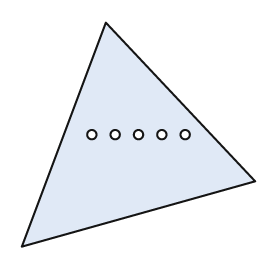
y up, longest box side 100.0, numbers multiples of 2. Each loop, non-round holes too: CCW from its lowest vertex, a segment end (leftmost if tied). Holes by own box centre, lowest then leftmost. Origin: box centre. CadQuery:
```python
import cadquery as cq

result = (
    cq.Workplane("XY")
    .moveTo(-50.0, -48.0)
    .lineTo(50.0, -20.0)
    .lineTo(-14.0, 48.0)
    .close()
    .moveTo(-20.0, 0.0)
    .circle(2.0)
    .moveTo(-10.0, 0.0)
    .circle(2.0)
    .moveTo(0.0, 0.0)
    .circle(2.0)
    .moveTo(10.0, 0.0)
    .circle(2.0)
    .moveTo(20.0, 0.0)
    .circle(2.0)
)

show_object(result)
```